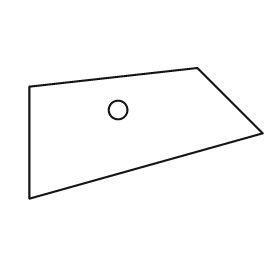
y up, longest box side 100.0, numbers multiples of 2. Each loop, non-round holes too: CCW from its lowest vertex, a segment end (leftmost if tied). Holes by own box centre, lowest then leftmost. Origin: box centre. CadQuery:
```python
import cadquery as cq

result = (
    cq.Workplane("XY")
    .moveTo(-50.0, -28.0)
    .lineTo(50.0, 0.0)
    .lineTo(22.0, 28.0)
    .lineTo(-50.0, 20.0)
    .close()
    .moveTo(-12.0, 10.0)
    .circle(4.0)
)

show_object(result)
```